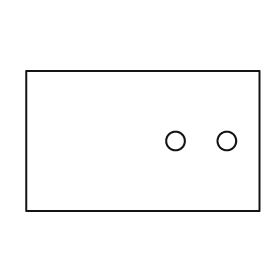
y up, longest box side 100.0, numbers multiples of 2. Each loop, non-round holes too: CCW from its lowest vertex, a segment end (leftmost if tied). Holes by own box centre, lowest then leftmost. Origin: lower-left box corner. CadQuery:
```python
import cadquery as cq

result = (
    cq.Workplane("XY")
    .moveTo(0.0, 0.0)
    .lineTo(100.0, 0.0)
    .lineTo(100.0, 60.0)
    .lineTo(0.0, 60.0)
    .close()
    .moveTo(64.0, 30.0)
    .circle(4.0)
    .moveTo(86.0, 30.0)
    .circle(4.0)
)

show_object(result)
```